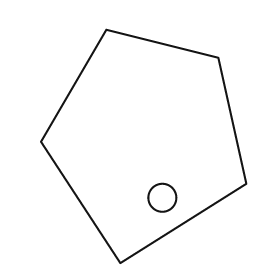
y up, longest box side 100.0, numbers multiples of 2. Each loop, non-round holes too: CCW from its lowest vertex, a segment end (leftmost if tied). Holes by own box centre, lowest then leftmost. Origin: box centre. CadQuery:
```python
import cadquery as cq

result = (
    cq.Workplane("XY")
    .moveTo(-10.0, -50.0)
    .lineTo(44.0, -16.0)
    .lineTo(32.0, 38.0)
    .lineTo(-16.0, 50.0)
    .lineTo(-44.0, 2.0)
    .close()
    .moveTo(8.0, -22.0)
    .circle(6.0)
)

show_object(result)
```